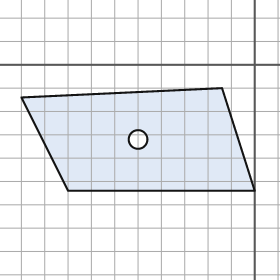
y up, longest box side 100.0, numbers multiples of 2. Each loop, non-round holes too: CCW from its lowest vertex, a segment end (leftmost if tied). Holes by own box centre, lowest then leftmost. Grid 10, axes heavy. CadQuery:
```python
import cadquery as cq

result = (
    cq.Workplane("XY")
    .moveTo(-80.0, -54.0)
    .lineTo(0.0, -54.0)
    .lineTo(-14.0, -10.0)
    .lineTo(-100.0, -14.0)
    .close()
    .moveTo(-50.0, -32.0)
    .circle(4.0)
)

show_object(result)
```